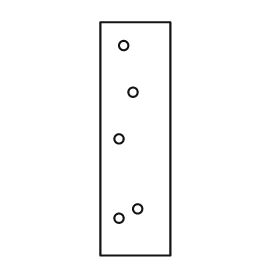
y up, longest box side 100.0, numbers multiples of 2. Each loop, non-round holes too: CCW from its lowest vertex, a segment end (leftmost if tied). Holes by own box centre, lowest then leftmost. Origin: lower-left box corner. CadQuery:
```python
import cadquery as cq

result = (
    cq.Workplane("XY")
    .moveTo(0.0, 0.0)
    .lineTo(30.0, 0.0)
    .lineTo(30.0, 100.0)
    .lineTo(0.0, 100.0)
    .close()
    .moveTo(8.0, 16.0)
    .circle(2.0)
    .moveTo(16.0, 20.0)
    .circle(2.0)
    .moveTo(8.0, 50.0)
    .circle(2.0)
    .moveTo(14.0, 70.0)
    .circle(2.0)
    .moveTo(10.0, 90.0)
    .circle(2.0)
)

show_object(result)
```